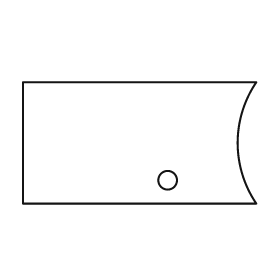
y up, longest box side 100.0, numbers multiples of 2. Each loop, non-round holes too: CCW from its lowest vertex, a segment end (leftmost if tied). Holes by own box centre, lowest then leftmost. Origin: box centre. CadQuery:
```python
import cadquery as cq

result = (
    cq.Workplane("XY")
    .moveTo(-50.0, -26.0)
    .lineTo(50.0, -26.0)
    .threePointArc((42.0, 0.0), (50.0, 26.0))
    .lineTo(-50.0, 26.0)
    .close()
    .moveTo(12.0, -16.0)
    .circle(4.0)
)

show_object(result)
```